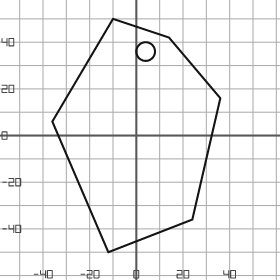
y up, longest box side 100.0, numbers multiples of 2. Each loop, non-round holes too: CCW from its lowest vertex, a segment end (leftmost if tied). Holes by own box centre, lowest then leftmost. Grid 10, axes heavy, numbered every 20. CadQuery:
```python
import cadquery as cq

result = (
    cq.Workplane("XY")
    .moveTo(-12.0, -50.0)
    .lineTo(24.0, -36.0)
    .lineTo(36.0, 16.0)
    .lineTo(14.0, 42.0)
    .lineTo(-10.0, 50.0)
    .lineTo(-36.0, 6.0)
    .close()
    .moveTo(4.0, 36.0)
    .circle(4.0)
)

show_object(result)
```